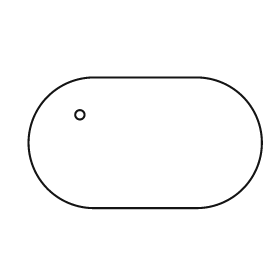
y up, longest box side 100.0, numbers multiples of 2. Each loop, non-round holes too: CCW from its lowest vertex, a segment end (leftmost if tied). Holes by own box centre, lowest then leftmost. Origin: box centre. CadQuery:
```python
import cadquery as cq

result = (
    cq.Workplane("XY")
    .moveTo(-22.0, -28.0)
    .lineTo(22.0, -28.0)
    .threePointArc((50.0, 0.0), (22.0, 28.0))
    .lineTo(-22.0, 28.0)
    .threePointArc((-50.0, 0.0), (-22.0, -28.0))
    .close()
    .moveTo(-28.0, 12.0)
    .circle(2.0)
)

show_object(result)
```